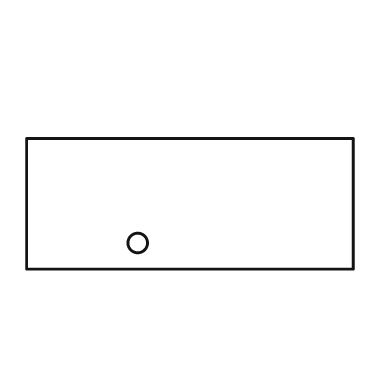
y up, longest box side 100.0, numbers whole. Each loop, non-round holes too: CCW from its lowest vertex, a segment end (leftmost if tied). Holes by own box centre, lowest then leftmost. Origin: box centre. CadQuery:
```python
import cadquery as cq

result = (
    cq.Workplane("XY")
    .moveTo(-50.0, -20.0)
    .lineTo(50.0, -20.0)
    .lineTo(50.0, 20.0)
    .lineTo(-50.0, 20.0)
    .close()
    .moveTo(-16.0, -12.0)
    .circle(3.0)
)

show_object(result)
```